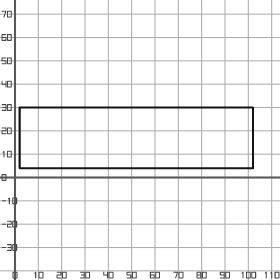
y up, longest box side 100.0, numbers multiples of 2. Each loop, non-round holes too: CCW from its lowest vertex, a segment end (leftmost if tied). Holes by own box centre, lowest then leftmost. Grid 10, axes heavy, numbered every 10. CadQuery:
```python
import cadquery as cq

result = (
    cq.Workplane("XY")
    .moveTo(2.0, 4.0)
    .lineTo(102.0, 4.0)
    .lineTo(102.0, 30.0)
    .lineTo(2.0, 30.0)
    .close()
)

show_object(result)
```